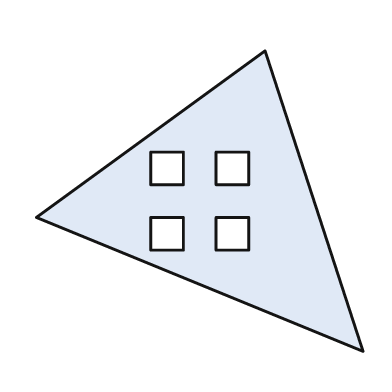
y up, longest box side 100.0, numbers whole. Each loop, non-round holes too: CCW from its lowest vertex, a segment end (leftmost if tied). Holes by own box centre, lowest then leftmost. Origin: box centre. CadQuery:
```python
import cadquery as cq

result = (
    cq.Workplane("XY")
    .moveTo(50.0, -46.0)
    .lineTo(20.0, 46.0)
    .lineTo(-50.0, -5.0)
    .close()
    .moveTo(-15.0, -15.0)
    .lineTo(-5.0, -15.0)
    .lineTo(-5.0, -5.0)
    .lineTo(-15.0, -5.0)
    .close()
    .moveTo(5.0, -15.0)
    .lineTo(15.0, -15.0)
    .lineTo(15.0, -5.0)
    .lineTo(5.0, -5.0)
    .close()
    .moveTo(-15.0, 5.0)
    .lineTo(-5.0, 5.0)
    .lineTo(-5.0, 15.0)
    .lineTo(-15.0, 15.0)
    .close()
    .moveTo(5.0, 5.0)
    .lineTo(15.0, 5.0)
    .lineTo(15.0, 15.0)
    .lineTo(5.0, 15.0)
    .close()
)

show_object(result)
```